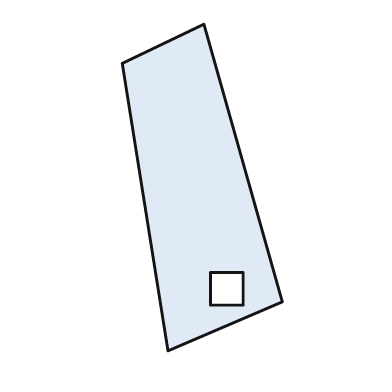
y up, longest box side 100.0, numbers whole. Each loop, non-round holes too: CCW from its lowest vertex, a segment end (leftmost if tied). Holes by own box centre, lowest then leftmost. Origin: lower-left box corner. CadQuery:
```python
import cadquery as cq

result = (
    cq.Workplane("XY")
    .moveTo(14.0, 0.0)
    .lineTo(49.0, 15.0)
    .lineTo(25.0, 100.0)
    .lineTo(0.0, 88.0)
    .close()
    .moveTo(27.0, 14.0)
    .lineTo(37.0, 14.0)
    .lineTo(37.0, 24.0)
    .lineTo(27.0, 24.0)
    .close()
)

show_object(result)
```